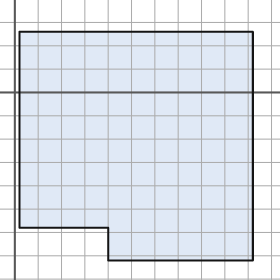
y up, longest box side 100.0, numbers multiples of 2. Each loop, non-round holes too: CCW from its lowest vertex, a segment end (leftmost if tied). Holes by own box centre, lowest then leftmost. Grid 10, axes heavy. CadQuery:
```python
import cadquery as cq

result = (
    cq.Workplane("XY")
    .moveTo(40.0, -72.0)
    .lineTo(102.0, -72.0)
    .lineTo(102.0, 26.0)
    .lineTo(2.0, 26.0)
    .lineTo(2.0, -58.0)
    .lineTo(40.0, -58.0)
    .close()
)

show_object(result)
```